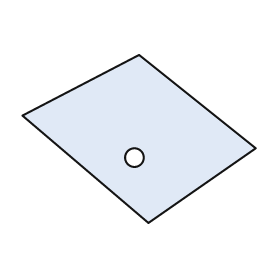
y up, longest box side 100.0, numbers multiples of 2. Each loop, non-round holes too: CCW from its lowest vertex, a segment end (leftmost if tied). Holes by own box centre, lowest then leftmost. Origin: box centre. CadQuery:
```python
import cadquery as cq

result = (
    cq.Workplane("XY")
    .moveTo(4.0, -36.0)
    .lineTo(50.0, -4.0)
    .lineTo(0.0, 36.0)
    .lineTo(-50.0, 10.0)
    .close()
    .moveTo(-2.0, -8.0)
    .circle(4.0)
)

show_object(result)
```